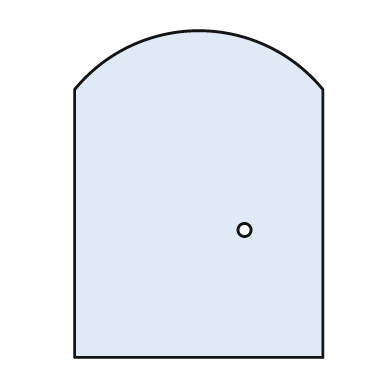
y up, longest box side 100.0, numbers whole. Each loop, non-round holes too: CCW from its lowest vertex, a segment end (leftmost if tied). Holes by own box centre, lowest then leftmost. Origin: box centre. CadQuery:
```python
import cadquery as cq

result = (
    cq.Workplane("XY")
    .moveTo(-38.0, -50.0)
    .lineTo(38.0, -50.0)
    .lineTo(38.0, 32.0)
    .threePointArc((0.0, 50.0), (-38.0, 32.0))
    .close()
    .moveTo(14.0, -11.0)
    .circle(2.0)
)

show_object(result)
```